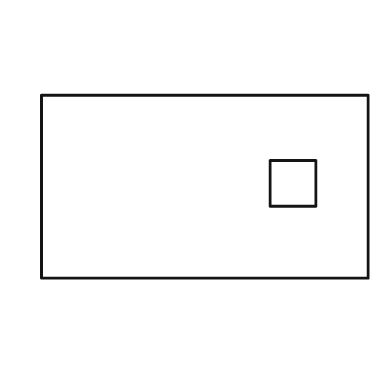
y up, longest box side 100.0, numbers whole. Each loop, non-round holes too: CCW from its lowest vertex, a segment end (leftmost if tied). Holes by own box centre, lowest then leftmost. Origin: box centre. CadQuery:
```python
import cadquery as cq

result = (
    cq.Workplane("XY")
    .moveTo(-50.0, -28.0)
    .lineTo(50.0, -28.0)
    .lineTo(50.0, 28.0)
    .lineTo(-50.0, 28.0)
    .close()
    .moveTo(20.0, -6.0)
    .lineTo(34.0, -6.0)
    .lineTo(34.0, 8.0)
    .lineTo(20.0, 8.0)
    .close()
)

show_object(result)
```